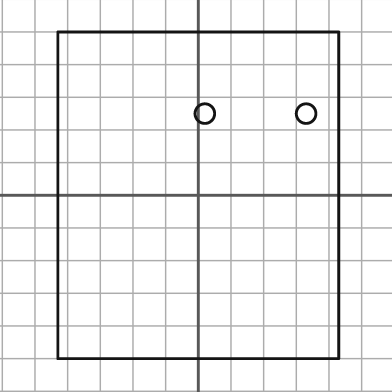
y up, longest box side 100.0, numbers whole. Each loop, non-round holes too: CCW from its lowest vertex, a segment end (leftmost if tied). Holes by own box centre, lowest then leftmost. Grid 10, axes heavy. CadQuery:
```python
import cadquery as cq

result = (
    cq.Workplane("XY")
    .moveTo(-43.0, -50.0)
    .lineTo(43.0, -50.0)
    .lineTo(43.0, 50.0)
    .lineTo(-43.0, 50.0)
    .close()
    .moveTo(2.0, 25.0)
    .circle(3.0)
    .moveTo(33.0, 25.0)
    .circle(3.0)
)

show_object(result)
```